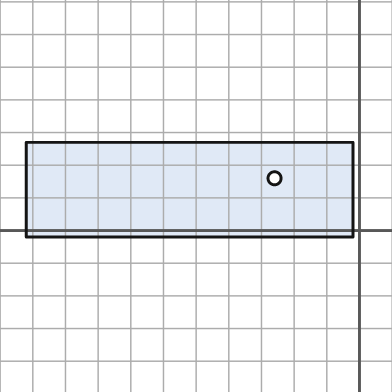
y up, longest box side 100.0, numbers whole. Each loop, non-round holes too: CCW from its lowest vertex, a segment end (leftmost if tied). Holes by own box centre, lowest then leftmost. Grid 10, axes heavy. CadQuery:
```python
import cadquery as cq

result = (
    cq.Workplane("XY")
    .moveTo(-102.0, -2.0)
    .lineTo(-2.0, -2.0)
    .lineTo(-2.0, 27.0)
    .lineTo(-102.0, 27.0)
    .close()
    .moveTo(-26.0, 16.0)
    .circle(2.0)
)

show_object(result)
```